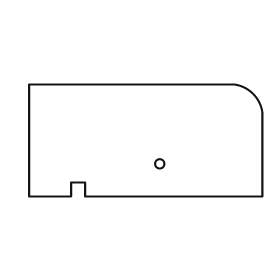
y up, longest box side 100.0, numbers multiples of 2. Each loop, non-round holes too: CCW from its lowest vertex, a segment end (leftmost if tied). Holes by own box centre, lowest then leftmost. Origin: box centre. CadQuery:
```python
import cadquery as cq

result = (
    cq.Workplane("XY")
    .moveTo(-50.0, -24.0)
    .lineTo(-32.0, -24.0)
    .lineTo(-32.0, -18.0)
    .lineTo(-26.0, -18.0)
    .lineTo(-26.0, -24.0)
    .lineTo(50.0, -24.0)
    .lineTo(50.0, 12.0)
    .threePointArc((46.0, 20.0), (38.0, 24.0))
    .lineTo(-50.0, 24.0)
    .close()
    .moveTo(6.0, -10.0)
    .circle(2.0)
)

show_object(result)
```